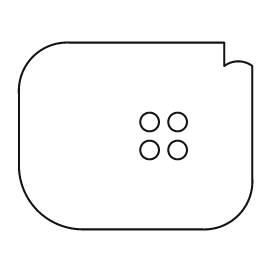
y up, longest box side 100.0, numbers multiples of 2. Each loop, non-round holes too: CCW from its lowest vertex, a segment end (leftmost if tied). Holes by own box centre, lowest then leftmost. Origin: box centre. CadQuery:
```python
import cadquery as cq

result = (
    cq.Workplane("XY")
    .moveTo(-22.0, -40.0)
    .lineTo(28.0, -40.0)
    .threePointArc((44.0, -34.0), (50.0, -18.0))
    .lineTo(50.0, 30.0)
    .threePointArc((44.0, 32.0), (38.0, 30.0))
    .lineTo(38.0, 40.0)
    .lineTo(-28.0, 40.0)
    .threePointArc((-44.0, 34.0), (-50.0, 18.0))
    .lineTo(-50.0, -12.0)
    .threePointArc((-42.0, -32.0), (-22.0, -40.0))
    .close()
    .moveTo(6.0, -6.0)
    .circle(4.0)
    .moveTo(18.0, -6.0)
    .circle(4.0)
    .moveTo(6.0, 6.0)
    .circle(4.0)
    .moveTo(18.0, 6.0)
    .circle(4.0)
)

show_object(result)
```